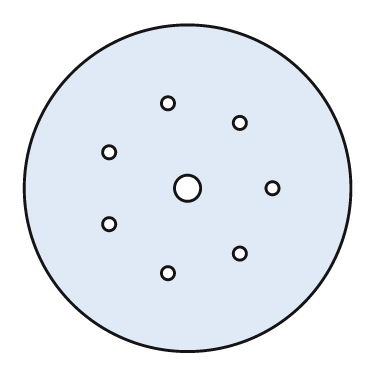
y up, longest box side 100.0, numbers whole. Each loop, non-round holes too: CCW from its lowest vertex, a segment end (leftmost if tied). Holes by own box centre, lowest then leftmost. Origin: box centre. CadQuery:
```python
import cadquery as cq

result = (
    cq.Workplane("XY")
    .moveTo(0.0, 0.0)
    .circle(50.0)
    .moveTo(-6.0, -26.0)
    .circle(2.0)
    .moveTo(16.0, -20.0)
    .circle(2.0)
    .moveTo(-24.0, -11.0)
    .circle(2.0)
    .moveTo(0.0, 0.0)
    .circle(4.0)
    .moveTo(26.0, 0.0)
    .circle(2.0)
    .moveTo(-24.0, 11.0)
    .circle(2.0)
    .moveTo(16.0, 20.0)
    .circle(2.0)
    .moveTo(-6.0, 26.0)
    .circle(2.0)
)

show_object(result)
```